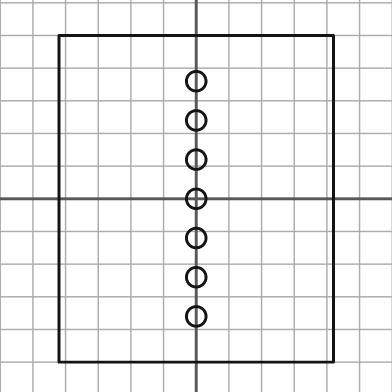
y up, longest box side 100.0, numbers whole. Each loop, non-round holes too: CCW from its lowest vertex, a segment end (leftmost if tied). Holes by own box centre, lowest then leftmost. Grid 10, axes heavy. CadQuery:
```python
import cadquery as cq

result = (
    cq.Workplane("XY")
    .moveTo(-42.0, -50.0)
    .lineTo(42.0, -50.0)
    .lineTo(42.0, 50.0)
    .lineTo(-42.0, 50.0)
    .close()
    .moveTo(0.0, -36.0)
    .circle(3.0)
    .moveTo(0.0, -24.0)
    .circle(3.0)
    .moveTo(0.0, -12.0)
    .circle(3.0)
    .moveTo(0.0, 0.0)
    .circle(3.0)
    .moveTo(0.0, 12.0)
    .circle(3.0)
    .moveTo(0.0, 24.0)
    .circle(3.0)
    .moveTo(0.0, 36.0)
    .circle(3.0)
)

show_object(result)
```